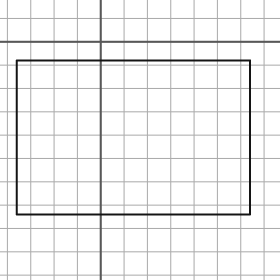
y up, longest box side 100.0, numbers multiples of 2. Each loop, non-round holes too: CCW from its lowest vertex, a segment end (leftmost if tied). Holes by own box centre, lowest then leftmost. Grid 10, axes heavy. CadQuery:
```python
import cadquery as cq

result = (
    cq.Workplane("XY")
    .moveTo(-36.0, -74.0)
    .lineTo(64.0, -74.0)
    .lineTo(64.0, -8.0)
    .lineTo(-36.0, -8.0)
    .close()
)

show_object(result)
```